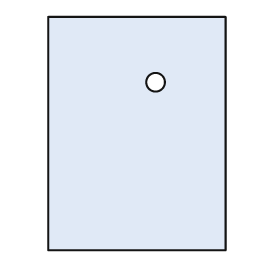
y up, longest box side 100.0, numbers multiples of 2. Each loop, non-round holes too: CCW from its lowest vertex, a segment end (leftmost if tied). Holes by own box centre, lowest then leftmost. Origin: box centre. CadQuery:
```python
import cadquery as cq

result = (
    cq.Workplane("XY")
    .moveTo(-38.0, -50.0)
    .lineTo(38.0, -50.0)
    .lineTo(38.0, 50.0)
    .lineTo(-38.0, 50.0)
    .close()
    .moveTo(8.0, 22.0)
    .circle(4.0)
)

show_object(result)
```